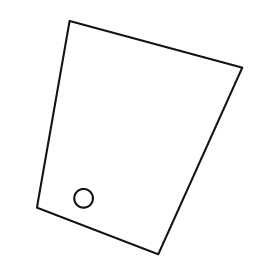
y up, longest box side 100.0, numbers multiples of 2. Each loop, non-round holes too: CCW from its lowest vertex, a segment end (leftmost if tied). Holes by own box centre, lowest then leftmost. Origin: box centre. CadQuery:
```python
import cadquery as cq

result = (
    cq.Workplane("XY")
    .moveTo(8.0, -50.0)
    .lineTo(44.0, 30.0)
    .lineTo(-30.0, 50.0)
    .lineTo(-44.0, -30.0)
    .close()
    .moveTo(-24.0, -26.0)
    .circle(4.0)
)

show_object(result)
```